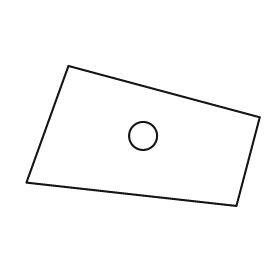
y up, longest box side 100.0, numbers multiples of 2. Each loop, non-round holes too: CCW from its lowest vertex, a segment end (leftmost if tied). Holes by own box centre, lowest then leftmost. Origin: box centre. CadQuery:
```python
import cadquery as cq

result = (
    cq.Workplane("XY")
    .moveTo(40.0, -30.0)
    .lineTo(50.0, 8.0)
    .lineTo(-32.0, 30.0)
    .lineTo(-50.0, -20.0)
    .close()
    .moveTo(0.0, 0.0)
    .circle(6.0)
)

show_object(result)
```